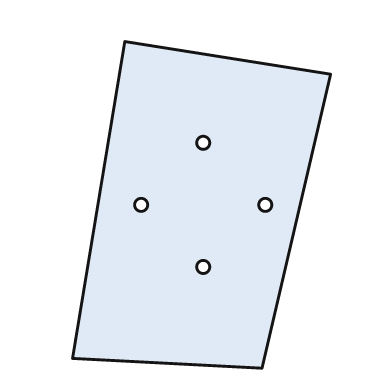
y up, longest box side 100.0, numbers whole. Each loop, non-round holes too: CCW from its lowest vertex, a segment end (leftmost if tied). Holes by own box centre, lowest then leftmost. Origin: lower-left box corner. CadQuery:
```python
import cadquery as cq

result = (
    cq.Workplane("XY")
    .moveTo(58.0, 0.0)
    .lineTo(79.0, 90.0)
    .lineTo(16.0, 100.0)
    .lineTo(0.0, 3.0)
    .close()
    .moveTo(40.0, 31.0)
    .circle(2.0)
    .moveTo(21.0, 50.0)
    .circle(2.0)
    .moveTo(59.0, 50.0)
    .circle(2.0)
    .moveTo(40.0, 69.0)
    .circle(2.0)
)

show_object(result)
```